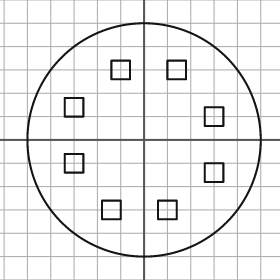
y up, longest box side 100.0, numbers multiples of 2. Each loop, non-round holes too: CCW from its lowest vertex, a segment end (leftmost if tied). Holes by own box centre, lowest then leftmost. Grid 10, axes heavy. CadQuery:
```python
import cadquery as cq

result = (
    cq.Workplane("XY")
    .moveTo(0.0, 0.0)
    .circle(50.0)
    .moveTo(-18.0, -34.0)
    .lineTo(-10.0, -34.0)
    .lineTo(-10.0, -26.0)
    .lineTo(-18.0, -26.0)
    .close()
    .moveTo(6.0, -34.0)
    .lineTo(14.0, -34.0)
    .lineTo(14.0, -26.0)
    .lineTo(6.0, -26.0)
    .close()
    .moveTo(26.0, -18.0)
    .lineTo(34.0, -18.0)
    .lineTo(34.0, -10.0)
    .lineTo(26.0, -10.0)
    .close()
    .moveTo(-34.0, -14.0)
    .lineTo(-26.0, -14.0)
    .lineTo(-26.0, -6.0)
    .lineTo(-34.0, -6.0)
    .close()
    .moveTo(26.0, 6.0)
    .lineTo(34.0, 6.0)
    .lineTo(34.0, 14.0)
    .lineTo(26.0, 14.0)
    .close()
    .moveTo(-34.0, 10.0)
    .lineTo(-26.0, 10.0)
    .lineTo(-26.0, 18.0)
    .lineTo(-34.0, 18.0)
    .close()
    .moveTo(-14.0, 26.0)
    .lineTo(-6.0, 26.0)
    .lineTo(-6.0, 34.0)
    .lineTo(-14.0, 34.0)
    .close()
    .moveTo(10.0, 26.0)
    .lineTo(18.0, 26.0)
    .lineTo(18.0, 34.0)
    .lineTo(10.0, 34.0)
    .close()
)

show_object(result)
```